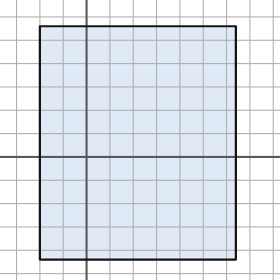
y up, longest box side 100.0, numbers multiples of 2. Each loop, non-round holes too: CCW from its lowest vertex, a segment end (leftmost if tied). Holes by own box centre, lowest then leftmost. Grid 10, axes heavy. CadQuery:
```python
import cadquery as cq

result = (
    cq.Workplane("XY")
    .moveTo(-20.0, -44.0)
    .lineTo(64.0, -44.0)
    .lineTo(64.0, 56.0)
    .lineTo(-20.0, 56.0)
    .close()
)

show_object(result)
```